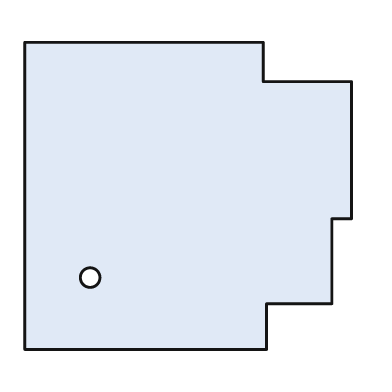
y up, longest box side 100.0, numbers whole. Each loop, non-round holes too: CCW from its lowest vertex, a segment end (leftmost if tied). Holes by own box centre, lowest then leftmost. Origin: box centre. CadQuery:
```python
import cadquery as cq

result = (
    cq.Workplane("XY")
    .moveTo(-50.0, -47.0)
    .lineTo(24.0, -47.0)
    .lineTo(24.0, -33.0)
    .lineTo(44.0, -33.0)
    .lineTo(44.0, -7.0)
    .lineTo(50.0, -7.0)
    .lineTo(50.0, 35.0)
    .lineTo(23.0, 35.0)
    .lineTo(23.0, 47.0)
    .lineTo(-50.0, 47.0)
    .close()
    .moveTo(-30.0, -25.0)
    .circle(3.0)
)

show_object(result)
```